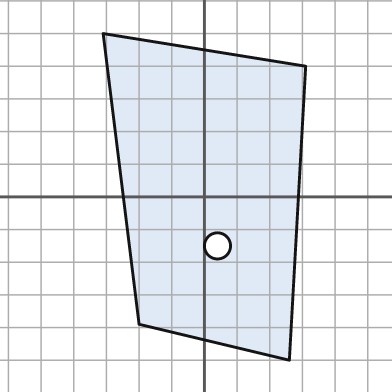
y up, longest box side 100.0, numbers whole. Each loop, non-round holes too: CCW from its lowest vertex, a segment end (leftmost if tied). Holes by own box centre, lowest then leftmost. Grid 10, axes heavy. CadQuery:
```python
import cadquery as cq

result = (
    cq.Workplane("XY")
    .moveTo(26.0, -50.0)
    .lineTo(31.0, 40.0)
    .lineTo(-31.0, 50.0)
    .lineTo(-20.0, -39.0)
    .close()
    .moveTo(4.0, -15.0)
    .circle(4.0)
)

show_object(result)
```